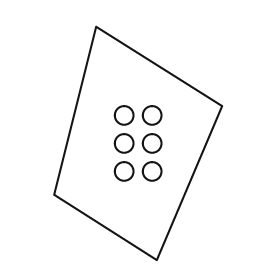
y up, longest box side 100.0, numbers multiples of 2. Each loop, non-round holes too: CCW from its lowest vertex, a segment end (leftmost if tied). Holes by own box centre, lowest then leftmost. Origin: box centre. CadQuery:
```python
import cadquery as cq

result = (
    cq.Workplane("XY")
    .moveTo(8.0, -50.0)
    .lineTo(36.0, 16.0)
    .lineTo(-18.0, 50.0)
    .lineTo(-36.0, -22.0)
    .close()
    .moveTo(-6.0, -12.0)
    .circle(4.0)
    .moveTo(6.0, -12.0)
    .circle(4.0)
    .moveTo(-6.0, 0.0)
    .circle(4.0)
    .moveTo(6.0, 0.0)
    .circle(4.0)
    .moveTo(-6.0, 12.0)
    .circle(4.0)
    .moveTo(6.0, 12.0)
    .circle(4.0)
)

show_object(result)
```